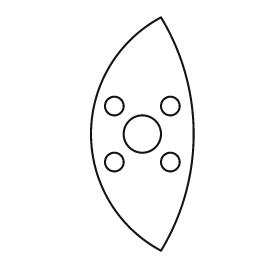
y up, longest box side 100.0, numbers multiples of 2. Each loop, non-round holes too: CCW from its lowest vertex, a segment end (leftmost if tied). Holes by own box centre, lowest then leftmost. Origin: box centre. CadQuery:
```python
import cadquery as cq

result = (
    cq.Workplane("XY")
    .moveTo(8.0, -50.0)
    .threePointArc((22.0, 0.0), (8.0, 50.0))
    .threePointArc((-22.0, 0.0), (8.0, -50.0))
    .close()
    .moveTo(-12.0, -12.0)
    .circle(4.0)
    .moveTo(12.0, -12.0)
    .circle(4.0)
    .moveTo(0.0, 0.0)
    .circle(8.0)
    .moveTo(-12.0, 12.0)
    .circle(4.0)
    .moveTo(12.0, 12.0)
    .circle(4.0)
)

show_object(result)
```